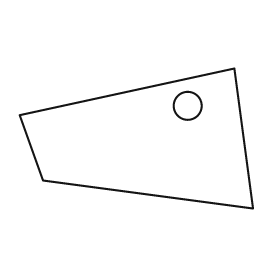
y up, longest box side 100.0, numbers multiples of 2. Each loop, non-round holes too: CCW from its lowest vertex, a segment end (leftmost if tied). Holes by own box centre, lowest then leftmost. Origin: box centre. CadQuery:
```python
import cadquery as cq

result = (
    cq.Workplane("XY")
    .moveTo(50.0, -30.0)
    .lineTo(42.0, 30.0)
    .lineTo(-50.0, 10.0)
    .lineTo(-40.0, -18.0)
    .close()
    .moveTo(22.0, 14.0)
    .circle(6.0)
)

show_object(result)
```